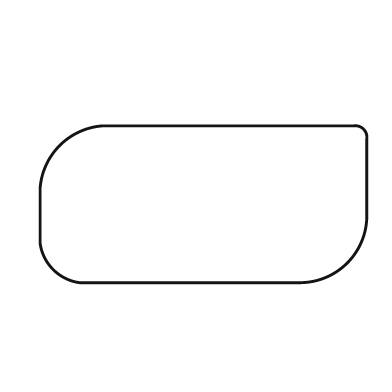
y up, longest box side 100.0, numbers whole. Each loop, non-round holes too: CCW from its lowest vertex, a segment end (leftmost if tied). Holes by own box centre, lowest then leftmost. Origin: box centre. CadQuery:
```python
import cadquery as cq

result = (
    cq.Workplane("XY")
    .moveTo(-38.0, -24.0)
    .lineTo(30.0, -24.0)
    .threePointArc((44.0, -18.0), (50.0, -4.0))
    .lineTo(50.0, 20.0)
    .threePointArc((49.0, 23.0), (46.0, 24.0))
    .lineTo(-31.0, 24.0)
    .threePointArc((-44.0, 18.0), (-50.0, 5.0))
    .lineTo(-50.0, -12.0)
    .threePointArc((-46.0, -20.0), (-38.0, -24.0))
    .close()
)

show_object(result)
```